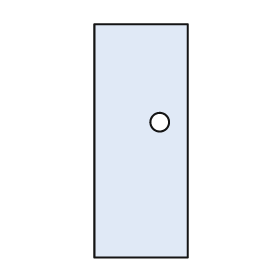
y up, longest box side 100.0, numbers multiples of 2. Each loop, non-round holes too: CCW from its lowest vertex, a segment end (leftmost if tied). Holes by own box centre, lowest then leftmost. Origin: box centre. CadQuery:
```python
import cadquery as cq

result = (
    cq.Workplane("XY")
    .moveTo(-20.0, -50.0)
    .lineTo(20.0, -50.0)
    .lineTo(20.0, 50.0)
    .lineTo(-20.0, 50.0)
    .close()
    .moveTo(8.0, 8.0)
    .circle(4.0)
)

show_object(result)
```